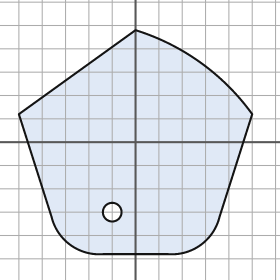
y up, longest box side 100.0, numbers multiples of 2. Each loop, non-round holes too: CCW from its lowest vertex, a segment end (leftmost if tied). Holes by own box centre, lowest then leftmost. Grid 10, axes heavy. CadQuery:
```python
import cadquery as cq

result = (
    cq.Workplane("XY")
    .moveTo(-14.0, -48.0)
    .lineTo(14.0, -48.0)
    .threePointArc((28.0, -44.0), (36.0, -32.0))
    .lineTo(50.0, 12.0)
    .threePointArc((28.0, 34.0), (0.0, 48.0))
    .lineTo(-50.0, 12.0)
    .lineTo(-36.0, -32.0)
    .threePointArc((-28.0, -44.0), (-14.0, -48.0))
    .close()
    .moveTo(-10.0, -30.0)
    .circle(4.0)
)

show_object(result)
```